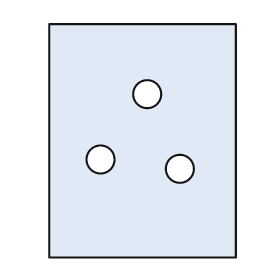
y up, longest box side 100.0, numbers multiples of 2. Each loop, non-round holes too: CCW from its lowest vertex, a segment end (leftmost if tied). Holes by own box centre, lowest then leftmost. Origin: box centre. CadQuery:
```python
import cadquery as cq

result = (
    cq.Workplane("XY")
    .moveTo(-40.0, -50.0)
    .lineTo(40.0, -50.0)
    .lineTo(40.0, 50.0)
    .lineTo(-40.0, 50.0)
    .close()
    .moveTo(16.0, -12.0)
    .circle(6.0)
    .moveTo(-18.0, -8.0)
    .circle(6.0)
    .moveTo(2.0, 20.0)
    .circle(6.0)
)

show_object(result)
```